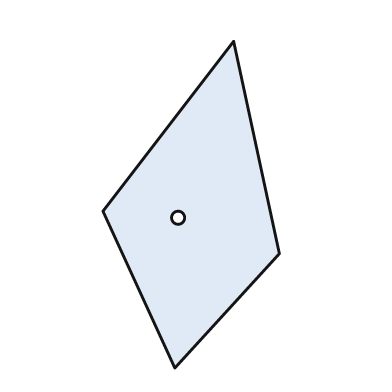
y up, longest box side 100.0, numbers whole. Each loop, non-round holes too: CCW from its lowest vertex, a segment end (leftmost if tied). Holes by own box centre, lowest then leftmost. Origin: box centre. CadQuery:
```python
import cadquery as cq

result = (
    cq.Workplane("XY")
    .moveTo(-5.0, -50.0)
    .lineTo(27.0, -15.0)
    .lineTo(13.0, 50.0)
    .lineTo(-27.0, -2.0)
    .close()
    .moveTo(-4.0, -4.0)
    .circle(2.0)
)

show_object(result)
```